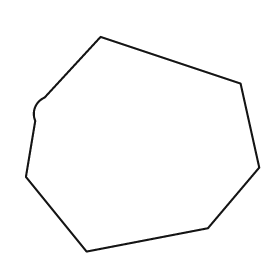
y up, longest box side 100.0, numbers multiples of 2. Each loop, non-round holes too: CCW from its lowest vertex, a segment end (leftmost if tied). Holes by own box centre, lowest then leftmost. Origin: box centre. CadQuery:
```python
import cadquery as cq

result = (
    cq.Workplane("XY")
    .moveTo(-24.0, -46.0)
    .lineTo(28.0, -36.0)
    .lineTo(50.0, -10.0)
    .lineTo(42.0, 26.0)
    .lineTo(-18.0, 46.0)
    .lineTo(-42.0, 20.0)
    .threePointArc((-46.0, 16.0), (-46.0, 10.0))
    .lineTo(-50.0, -14.0)
    .close()
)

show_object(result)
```